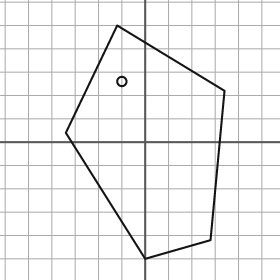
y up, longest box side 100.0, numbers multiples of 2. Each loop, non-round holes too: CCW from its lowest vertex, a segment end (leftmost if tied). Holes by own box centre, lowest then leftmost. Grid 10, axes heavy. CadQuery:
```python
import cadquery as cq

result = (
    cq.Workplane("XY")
    .moveTo(0.0, -50.0)
    .lineTo(28.0, -42.0)
    .lineTo(34.0, 22.0)
    .lineTo(-12.0, 50.0)
    .lineTo(-34.0, 4.0)
    .close()
    .moveTo(-10.0, 26.0)
    .circle(2.0)
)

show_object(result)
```